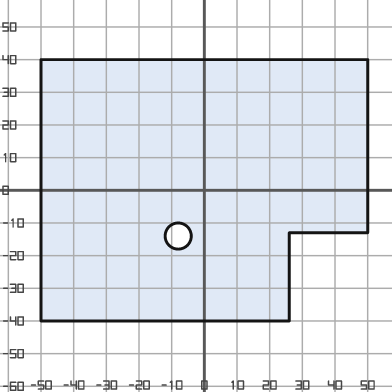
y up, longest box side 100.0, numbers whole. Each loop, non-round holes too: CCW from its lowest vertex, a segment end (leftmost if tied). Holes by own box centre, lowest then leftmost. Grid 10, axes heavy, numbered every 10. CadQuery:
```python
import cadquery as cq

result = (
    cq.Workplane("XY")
    .moveTo(-50.0, -40.0)
    .lineTo(26.0, -40.0)
    .lineTo(26.0, -13.0)
    .lineTo(50.0, -13.0)
    .lineTo(50.0, 40.0)
    .lineTo(-50.0, 40.0)
    .close()
    .moveTo(-8.0, -14.0)
    .circle(4.0)
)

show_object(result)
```